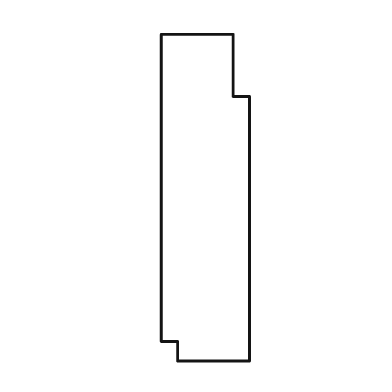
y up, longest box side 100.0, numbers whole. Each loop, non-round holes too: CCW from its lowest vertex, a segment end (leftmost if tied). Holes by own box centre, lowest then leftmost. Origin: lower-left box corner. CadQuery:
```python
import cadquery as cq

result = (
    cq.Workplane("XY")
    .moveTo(5.0, 0.0)
    .lineTo(27.0, 0.0)
    .lineTo(27.0, 81.0)
    .lineTo(22.0, 81.0)
    .lineTo(22.0, 100.0)
    .lineTo(0.0, 100.0)
    .lineTo(0.0, 6.0)
    .lineTo(5.0, 6.0)
    .close()
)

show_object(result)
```